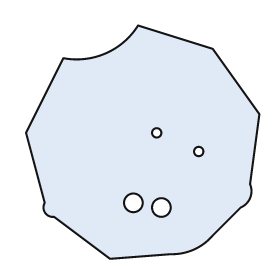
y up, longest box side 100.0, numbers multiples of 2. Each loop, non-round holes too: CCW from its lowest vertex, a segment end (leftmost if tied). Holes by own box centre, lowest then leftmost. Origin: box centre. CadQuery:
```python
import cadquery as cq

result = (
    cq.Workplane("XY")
    .moveTo(-14.0, -50.0)
    .lineTo(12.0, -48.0)
    .threePointArc((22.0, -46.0), (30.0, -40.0))
    .lineTo(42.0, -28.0)
    .threePointArc((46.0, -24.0), (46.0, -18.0))
    .lineTo(50.0, 12.0)
    .lineTo(30.0, 40.0)
    .lineTo(-2.0, 50.0)
    .threePointArc((-16.0, 38.0), (-34.0, 36.0))
    .lineTo(-50.0, 4.0)
    .lineTo(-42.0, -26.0)
    .threePointArc((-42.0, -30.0), (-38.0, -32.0))
    .close()
    .moveTo(8.0, -28.0)
    .circle(4.0)
    .moveTo(-4.0, -26.0)
    .circle(4.0)
    .moveTo(24.0, -4.0)
    .circle(2.0)
    .moveTo(6.0, 4.0)
    .circle(2.0)
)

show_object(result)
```